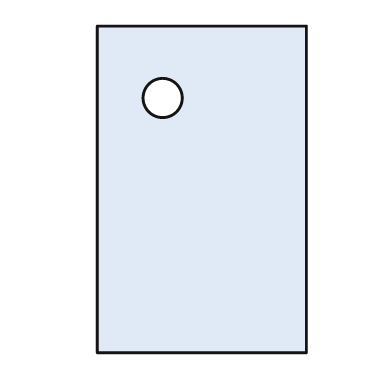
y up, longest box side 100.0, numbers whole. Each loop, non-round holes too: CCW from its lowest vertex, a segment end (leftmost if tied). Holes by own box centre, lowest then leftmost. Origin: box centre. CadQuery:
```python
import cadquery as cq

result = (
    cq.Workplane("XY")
    .moveTo(-32.0, -50.0)
    .lineTo(32.0, -50.0)
    .lineTo(32.0, 50.0)
    .lineTo(-32.0, 50.0)
    .close()
    .moveTo(-12.0, 28.0)
    .circle(6.0)
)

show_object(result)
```